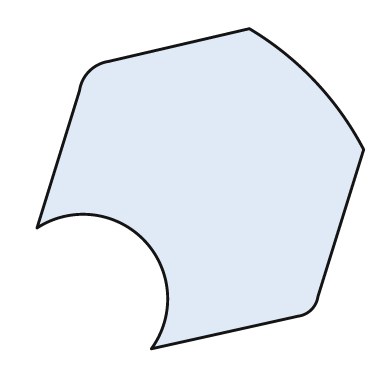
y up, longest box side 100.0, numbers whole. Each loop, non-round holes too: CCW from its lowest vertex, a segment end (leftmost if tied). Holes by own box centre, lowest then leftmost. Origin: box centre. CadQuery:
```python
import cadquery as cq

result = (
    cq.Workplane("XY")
    .moveTo(-15.0, -49.0)
    .lineTo(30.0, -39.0)
    .threePointArc((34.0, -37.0), (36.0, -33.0))
    .lineTo(50.0, 12.0)
    .threePointArc((35.0, 33.0), (15.0, 49.0))
    .lineTo(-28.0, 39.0)
    .threePointArc((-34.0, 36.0), (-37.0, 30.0))
    .lineTo(-50.0, -12.0)
    .threePointArc((-17.0, -16.0), (-15.0, -49.0))
    .close()
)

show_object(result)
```